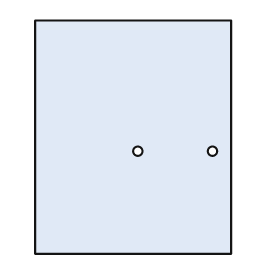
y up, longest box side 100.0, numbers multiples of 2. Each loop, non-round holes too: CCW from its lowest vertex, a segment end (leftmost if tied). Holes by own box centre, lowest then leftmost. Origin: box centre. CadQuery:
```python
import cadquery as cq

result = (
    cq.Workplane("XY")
    .moveTo(-42.0, -50.0)
    .lineTo(42.0, -50.0)
    .lineTo(42.0, 50.0)
    .lineTo(-42.0, 50.0)
    .close()
    .moveTo(2.0, -6.0)
    .circle(2.0)
    .moveTo(34.0, -6.0)
    .circle(2.0)
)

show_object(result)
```